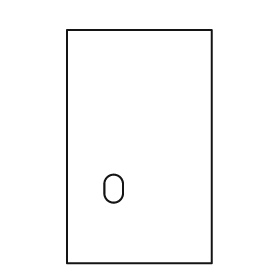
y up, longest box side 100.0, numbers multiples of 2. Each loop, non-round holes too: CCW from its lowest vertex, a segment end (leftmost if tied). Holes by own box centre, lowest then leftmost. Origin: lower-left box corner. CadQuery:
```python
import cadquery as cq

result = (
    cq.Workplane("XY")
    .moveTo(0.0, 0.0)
    .lineTo(62.0, 0.0)
    .lineTo(62.0, 100.0)
    .lineTo(0.0, 100.0)
    .close()
    .moveTo(16.0, 30.0)
    .threePointArc((20.0, 26.0), (24.0, 30.0))
    .lineTo(24.0, 34.0)
    .threePointArc((20.0, 38.0), (16.0, 34.0))
    .close()
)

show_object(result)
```